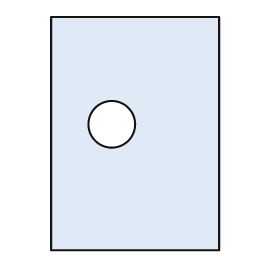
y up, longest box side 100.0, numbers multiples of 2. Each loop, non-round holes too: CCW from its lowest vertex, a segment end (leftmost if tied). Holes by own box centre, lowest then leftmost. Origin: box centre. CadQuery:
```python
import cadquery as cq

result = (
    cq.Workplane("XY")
    .moveTo(-36.0, -50.0)
    .lineTo(36.0, -50.0)
    .lineTo(36.0, 50.0)
    .lineTo(-36.0, 50.0)
    .close()
    .moveTo(-10.0, 4.0)
    .circle(10.0)
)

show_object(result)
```